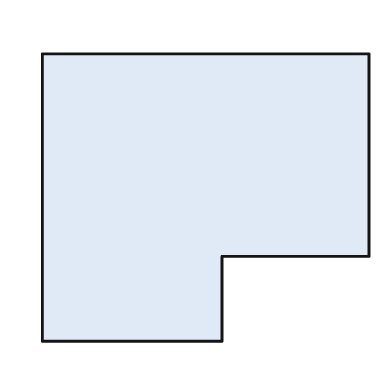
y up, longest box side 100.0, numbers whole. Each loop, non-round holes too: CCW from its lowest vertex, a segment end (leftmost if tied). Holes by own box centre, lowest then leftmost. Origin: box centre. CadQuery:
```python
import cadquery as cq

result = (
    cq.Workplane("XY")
    .moveTo(-50.0, -44.0)
    .lineTo(5.0, -44.0)
    .lineTo(5.0, -18.0)
    .lineTo(50.0, -18.0)
    .lineTo(50.0, 44.0)
    .lineTo(-50.0, 44.0)
    .close()
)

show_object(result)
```